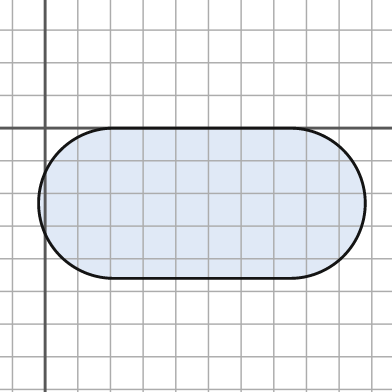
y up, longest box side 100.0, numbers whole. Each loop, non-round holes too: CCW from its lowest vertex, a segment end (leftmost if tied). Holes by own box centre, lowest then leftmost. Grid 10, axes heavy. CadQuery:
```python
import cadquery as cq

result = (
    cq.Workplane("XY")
    .moveTo(21.0, -46.0)
    .lineTo(75.0, -46.0)
    .threePointArc((98.0, -23.0), (75.0, 0.0))
    .lineTo(21.0, 0.0)
    .threePointArc((-2.0, -23.0), (21.0, -46.0))
    .close()
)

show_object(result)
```